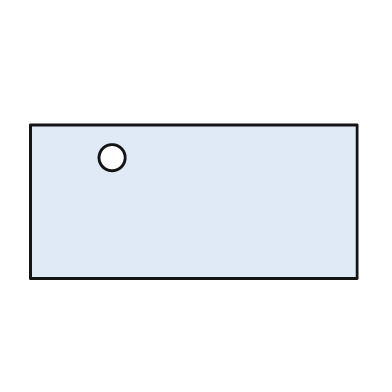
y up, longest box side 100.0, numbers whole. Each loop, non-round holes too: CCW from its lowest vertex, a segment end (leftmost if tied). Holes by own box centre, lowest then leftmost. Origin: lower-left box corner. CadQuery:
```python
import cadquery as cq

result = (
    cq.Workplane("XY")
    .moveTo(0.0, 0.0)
    .lineTo(100.0, 0.0)
    .lineTo(100.0, 47.0)
    .lineTo(0.0, 47.0)
    .close()
    .moveTo(25.0, 37.0)
    .circle(4.0)
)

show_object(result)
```